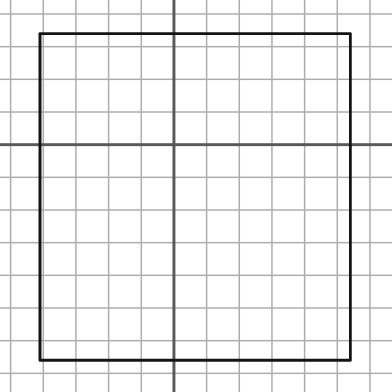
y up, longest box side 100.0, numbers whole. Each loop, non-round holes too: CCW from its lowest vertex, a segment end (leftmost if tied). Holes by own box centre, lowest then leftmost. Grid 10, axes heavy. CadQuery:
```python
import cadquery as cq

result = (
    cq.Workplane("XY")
    .moveTo(-41.0, -66.0)
    .lineTo(54.0, -66.0)
    .lineTo(54.0, 34.0)
    .lineTo(-41.0, 34.0)
    .close()
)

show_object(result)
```